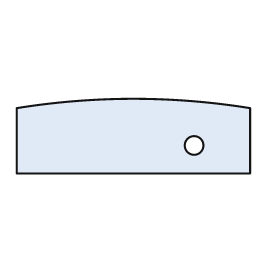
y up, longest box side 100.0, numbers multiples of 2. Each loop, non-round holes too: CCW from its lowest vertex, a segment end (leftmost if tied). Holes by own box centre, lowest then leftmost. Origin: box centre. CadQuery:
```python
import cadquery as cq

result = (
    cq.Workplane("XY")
    .moveTo(-50.0, -16.0)
    .lineTo(50.0, -16.0)
    .lineTo(50.0, 12.0)
    .threePointArc((0.0, 16.0), (-50.0, 12.0))
    .close()
    .moveTo(26.0, -4.0)
    .circle(4.0)
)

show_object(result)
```